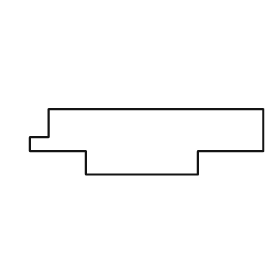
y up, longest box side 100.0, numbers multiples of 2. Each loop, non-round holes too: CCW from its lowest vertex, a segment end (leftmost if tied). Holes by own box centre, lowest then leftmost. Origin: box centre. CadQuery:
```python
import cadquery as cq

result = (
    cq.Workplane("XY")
    .moveTo(-26.0, -14.0)
    .lineTo(22.0, -14.0)
    .lineTo(22.0, -4.0)
    .lineTo(50.0, -4.0)
    .lineTo(50.0, 14.0)
    .lineTo(-42.0, 14.0)
    .lineTo(-42.0, 2.0)
    .lineTo(-50.0, 2.0)
    .lineTo(-50.0, -4.0)
    .lineTo(-26.0, -4.0)
    .close()
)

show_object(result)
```